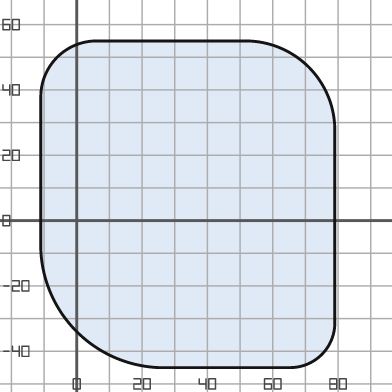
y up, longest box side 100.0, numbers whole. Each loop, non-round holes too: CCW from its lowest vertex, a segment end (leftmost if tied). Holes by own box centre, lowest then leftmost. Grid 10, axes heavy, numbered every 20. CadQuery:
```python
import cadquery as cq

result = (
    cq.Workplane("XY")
    .moveTo(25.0, -45.0)
    .lineTo(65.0, -45.0)
    .threePointArc((75.0, -41.0), (79.0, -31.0))
    .lineTo(79.0, 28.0)
    .threePointArc((71.0, 47.0), (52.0, 55.0))
    .lineTo(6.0, 55.0)
    .threePointArc((-6.0, 50.0), (-11.0, 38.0))
    .lineTo(-11.0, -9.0)
    .threePointArc((0.0, -34.0), (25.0, -45.0))
    .close()
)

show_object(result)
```